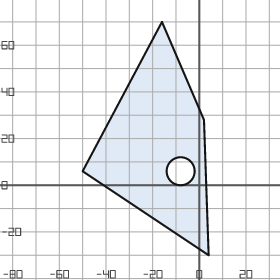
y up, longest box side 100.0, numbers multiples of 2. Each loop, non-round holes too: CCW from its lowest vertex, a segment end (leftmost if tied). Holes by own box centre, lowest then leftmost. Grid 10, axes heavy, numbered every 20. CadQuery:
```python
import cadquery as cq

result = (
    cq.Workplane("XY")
    .moveTo(4.0, -30.0)
    .lineTo(2.0, 28.0)
    .lineTo(-16.0, 70.0)
    .lineTo(-50.0, 6.0)
    .close()
    .moveTo(-8.0, 6.0)
    .circle(6.0)
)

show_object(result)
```